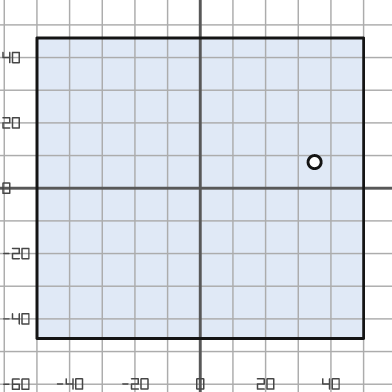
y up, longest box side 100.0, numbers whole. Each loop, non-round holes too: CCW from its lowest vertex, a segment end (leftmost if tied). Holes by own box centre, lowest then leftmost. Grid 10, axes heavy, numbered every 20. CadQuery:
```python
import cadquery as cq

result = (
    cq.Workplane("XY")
    .moveTo(-50.0, -46.0)
    .lineTo(50.0, -46.0)
    .lineTo(50.0, 46.0)
    .lineTo(-50.0, 46.0)
    .close()
    .moveTo(35.0, 8.0)
    .circle(2.0)
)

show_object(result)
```